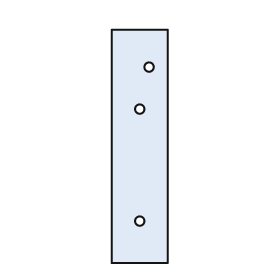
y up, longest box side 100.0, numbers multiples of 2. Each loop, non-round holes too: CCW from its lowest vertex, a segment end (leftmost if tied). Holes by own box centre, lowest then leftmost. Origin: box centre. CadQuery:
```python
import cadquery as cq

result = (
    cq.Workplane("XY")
    .moveTo(-12.0, -50.0)
    .lineTo(12.0, -50.0)
    .lineTo(12.0, 50.0)
    .lineTo(-12.0, 50.0)
    .close()
    .moveTo(0.0, -32.0)
    .circle(2.0)
    .moveTo(0.0, 16.0)
    .circle(2.0)
    .moveTo(4.0, 34.0)
    .circle(2.0)
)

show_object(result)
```